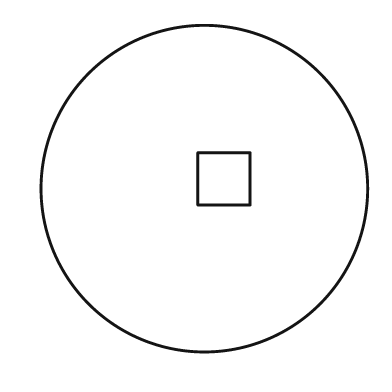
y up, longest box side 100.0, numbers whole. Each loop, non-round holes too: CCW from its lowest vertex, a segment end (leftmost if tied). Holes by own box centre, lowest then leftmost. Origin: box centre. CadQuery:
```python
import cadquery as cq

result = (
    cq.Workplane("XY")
    .moveTo(0.0, 0.0)
    .circle(50.0)
    .moveTo(-2.0, -5.0)
    .lineTo(14.0, -5.0)
    .lineTo(14.0, 11.0)
    .lineTo(-2.0, 11.0)
    .close()
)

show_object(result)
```